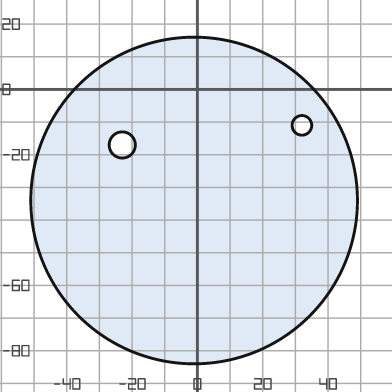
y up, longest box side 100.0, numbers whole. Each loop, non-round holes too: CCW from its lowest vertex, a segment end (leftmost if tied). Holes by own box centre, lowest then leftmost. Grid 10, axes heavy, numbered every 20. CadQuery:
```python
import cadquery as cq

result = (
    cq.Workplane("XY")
    .moveTo(-1.0, -34.0)
    .circle(50.0)
    .moveTo(-23.0, -17.0)
    .circle(4.0)
    .moveTo(32.0, -11.0)
    .circle(3.0)
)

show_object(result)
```